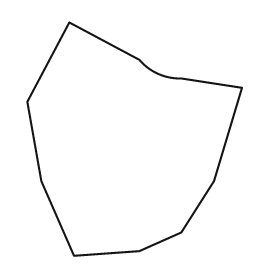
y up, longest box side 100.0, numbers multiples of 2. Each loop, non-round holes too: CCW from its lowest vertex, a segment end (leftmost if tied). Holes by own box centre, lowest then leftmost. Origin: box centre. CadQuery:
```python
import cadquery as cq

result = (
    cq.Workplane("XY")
    .moveTo(-26.0, -50.0)
    .lineTo(2.0, -48.0)
    .lineTo(20.0, -40.0)
    .lineTo(34.0, -18.0)
    .lineTo(46.0, 22.0)
    .lineTo(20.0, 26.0)
    .threePointArc((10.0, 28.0), (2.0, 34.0))
    .lineTo(-28.0, 50.0)
    .lineTo(-46.0, 16.0)
    .lineTo(-40.0, -18.0)
    .close()
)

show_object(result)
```